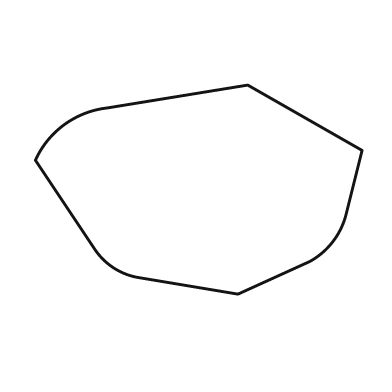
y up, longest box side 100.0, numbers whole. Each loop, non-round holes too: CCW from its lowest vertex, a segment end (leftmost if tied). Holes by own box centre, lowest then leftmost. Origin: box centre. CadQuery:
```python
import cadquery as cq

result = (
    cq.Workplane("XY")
    .moveTo(12.0, -32.0)
    .lineTo(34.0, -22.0)
    .threePointArc((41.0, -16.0), (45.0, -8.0))
    .lineTo(50.0, 12.0)
    .lineTo(15.0, 32.0)
    .lineTo(-28.0, 25.0)
    .threePointArc((-41.0, 20.0), (-50.0, 9.0))
    .lineTo(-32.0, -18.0)
    .threePointArc((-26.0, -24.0), (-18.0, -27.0))
    .close()
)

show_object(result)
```